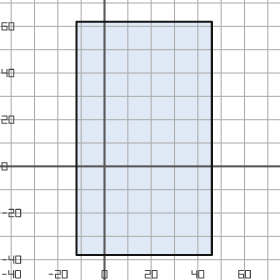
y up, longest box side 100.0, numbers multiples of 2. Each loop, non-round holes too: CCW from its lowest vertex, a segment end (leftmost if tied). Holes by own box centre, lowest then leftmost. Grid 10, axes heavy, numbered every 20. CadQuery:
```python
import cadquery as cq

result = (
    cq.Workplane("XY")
    .moveTo(-12.0, -38.0)
    .lineTo(46.0, -38.0)
    .lineTo(46.0, 62.0)
    .lineTo(-12.0, 62.0)
    .close()
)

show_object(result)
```